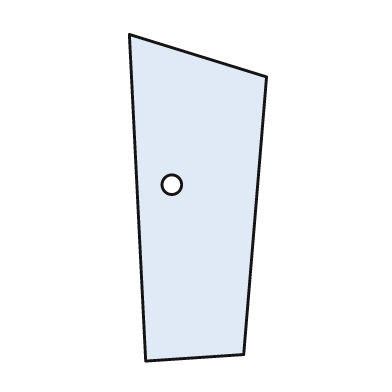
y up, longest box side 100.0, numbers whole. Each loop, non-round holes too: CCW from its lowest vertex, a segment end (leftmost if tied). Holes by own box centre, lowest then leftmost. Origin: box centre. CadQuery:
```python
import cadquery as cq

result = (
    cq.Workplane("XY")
    .moveTo(-16.0, -50.0)
    .lineTo(14.0, -48.0)
    .lineTo(21.0, 37.0)
    .lineTo(-21.0, 50.0)
    .close()
    .moveTo(-8.0, 4.0)
    .circle(3.0)
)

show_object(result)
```